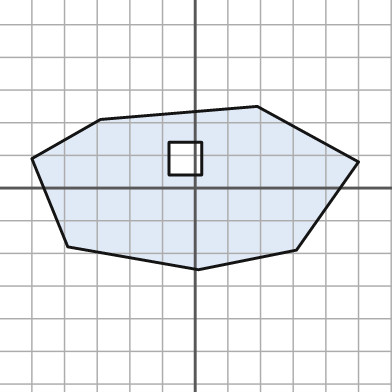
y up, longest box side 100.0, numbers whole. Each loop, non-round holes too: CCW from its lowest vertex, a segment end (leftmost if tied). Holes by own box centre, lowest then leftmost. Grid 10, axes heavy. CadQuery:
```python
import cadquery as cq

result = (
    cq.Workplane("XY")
    .moveTo(1.0, -25.0)
    .lineTo(31.0, -19.0)
    .lineTo(50.0, 8.0)
    .lineTo(19.0, 25.0)
    .lineTo(-29.0, 21.0)
    .lineTo(-50.0, 9.0)
    .lineTo(-39.0, -18.0)
    .close()
    .moveTo(-8.0, 4.0)
    .lineTo(2.0, 4.0)
    .lineTo(2.0, 14.0)
    .lineTo(-8.0, 14.0)
    .close()
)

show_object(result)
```